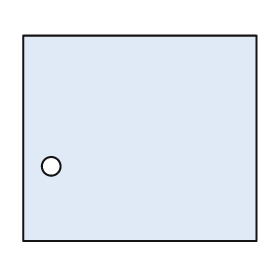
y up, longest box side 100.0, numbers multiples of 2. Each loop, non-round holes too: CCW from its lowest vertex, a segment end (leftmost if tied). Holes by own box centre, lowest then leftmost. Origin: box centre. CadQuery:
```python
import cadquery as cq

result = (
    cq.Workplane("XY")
    .moveTo(-50.0, -44.0)
    .lineTo(50.0, -44.0)
    .lineTo(50.0, 44.0)
    .lineTo(-50.0, 44.0)
    .close()
    .moveTo(-38.0, -12.0)
    .circle(4.0)
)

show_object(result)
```